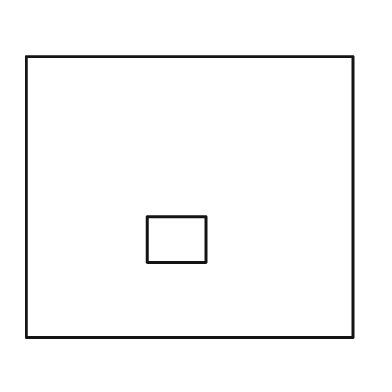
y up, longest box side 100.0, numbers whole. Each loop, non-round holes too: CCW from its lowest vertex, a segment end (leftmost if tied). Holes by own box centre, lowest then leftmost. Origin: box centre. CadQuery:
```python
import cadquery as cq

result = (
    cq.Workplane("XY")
    .moveTo(-50.0, -43.0)
    .lineTo(50.0, -43.0)
    .lineTo(50.0, 43.0)
    .lineTo(-50.0, 43.0)
    .close()
    .moveTo(-13.0, -20.0)
    .lineTo(5.0, -20.0)
    .lineTo(5.0, -6.0)
    .lineTo(-13.0, -6.0)
    .close()
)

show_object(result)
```